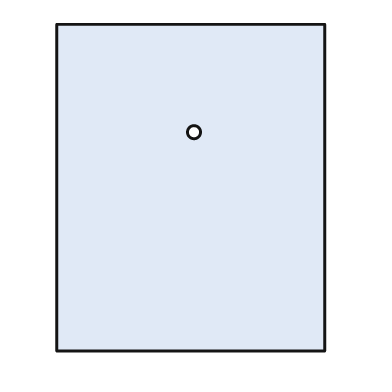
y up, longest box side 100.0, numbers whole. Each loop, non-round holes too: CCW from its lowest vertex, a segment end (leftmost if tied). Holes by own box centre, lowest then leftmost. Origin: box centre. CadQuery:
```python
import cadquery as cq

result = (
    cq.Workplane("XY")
    .moveTo(-41.0, -50.0)
    .lineTo(41.0, -50.0)
    .lineTo(41.0, 50.0)
    .lineTo(-41.0, 50.0)
    .close()
    .moveTo(1.0, 17.0)
    .circle(2.0)
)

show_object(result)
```